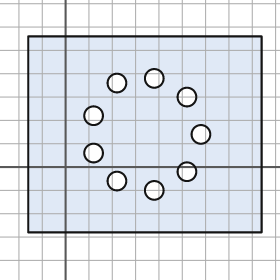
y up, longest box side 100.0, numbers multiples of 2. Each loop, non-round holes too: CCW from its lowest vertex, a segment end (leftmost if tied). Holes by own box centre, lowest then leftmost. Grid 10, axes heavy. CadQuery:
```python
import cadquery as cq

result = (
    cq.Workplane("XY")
    .moveTo(-16.0, -28.0)
    .lineTo(84.0, -28.0)
    .lineTo(84.0, 56.0)
    .lineTo(-16.0, 56.0)
    .close()
    .moveTo(38.0, -10.0)
    .circle(4.0)
    .moveTo(22.0, -6.0)
    .circle(4.0)
    .moveTo(52.0, -2.0)
    .circle(4.0)
    .moveTo(12.0, 6.0)
    .circle(4.0)
    .moveTo(58.0, 14.0)
    .circle(4.0)
    .moveTo(12.0, 22.0)
    .circle(4.0)
    .moveTo(52.0, 30.0)
    .circle(4.0)
    .moveTo(22.0, 36.0)
    .circle(4.0)
    .moveTo(38.0, 38.0)
    .circle(4.0)
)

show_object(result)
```